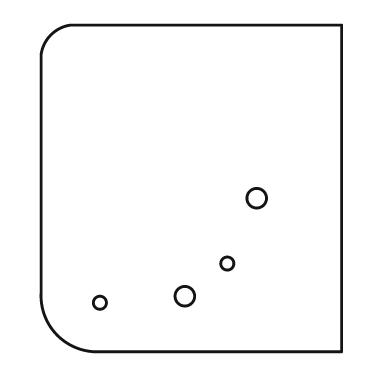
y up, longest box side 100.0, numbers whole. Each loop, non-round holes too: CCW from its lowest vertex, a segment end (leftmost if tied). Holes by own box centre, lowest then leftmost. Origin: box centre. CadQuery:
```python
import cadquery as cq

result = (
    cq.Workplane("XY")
    .moveTo(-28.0, -50.0)
    .lineTo(46.0, -50.0)
    .lineTo(46.0, 50.0)
    .lineTo(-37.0, 50.0)
    .threePointArc((-43.0, 47.0), (-46.0, 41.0))
    .lineTo(-46.0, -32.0)
    .threePointArc((-41.0, -45.0), (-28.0, -50.0))
    .close()
    .moveTo(-28.0, -35.0)
    .circle(2.0)
    .moveTo(-2.0, -33.0)
    .circle(3.0)
    .moveTo(11.0, -23.0)
    .circle(2.0)
    .moveTo(20.0, -3.0)
    .circle(3.0)
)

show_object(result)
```